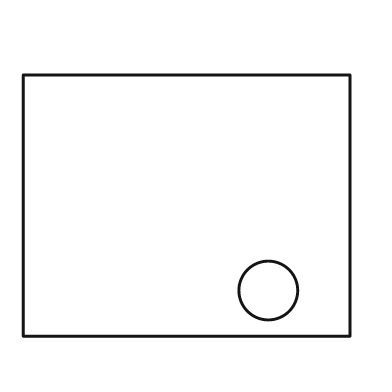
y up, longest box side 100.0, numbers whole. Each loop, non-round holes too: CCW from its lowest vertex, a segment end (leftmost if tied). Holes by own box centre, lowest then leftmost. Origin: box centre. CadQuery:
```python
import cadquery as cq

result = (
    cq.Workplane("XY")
    .moveTo(-50.0, -40.0)
    .lineTo(50.0, -40.0)
    .lineTo(50.0, 40.0)
    .lineTo(-50.0, 40.0)
    .close()
    .moveTo(25.0, -26.0)
    .circle(9.0)
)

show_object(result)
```